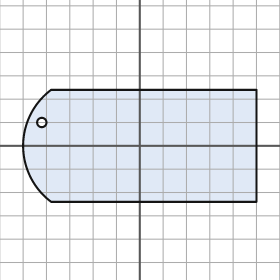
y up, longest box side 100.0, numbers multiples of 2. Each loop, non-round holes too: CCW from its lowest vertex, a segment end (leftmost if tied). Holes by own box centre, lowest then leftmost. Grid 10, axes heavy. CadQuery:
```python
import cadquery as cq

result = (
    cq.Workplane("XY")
    .moveTo(-38.0, -24.0)
    .lineTo(50.0, -24.0)
    .lineTo(50.0, 24.0)
    .lineTo(-38.0, 24.0)
    .threePointArc((-50.0, 0.0), (-38.0, -24.0))
    .close()
    .moveTo(-42.0, 10.0)
    .circle(2.0)
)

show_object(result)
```